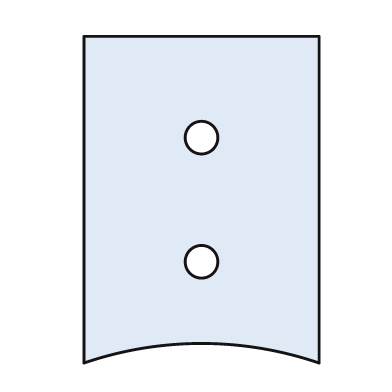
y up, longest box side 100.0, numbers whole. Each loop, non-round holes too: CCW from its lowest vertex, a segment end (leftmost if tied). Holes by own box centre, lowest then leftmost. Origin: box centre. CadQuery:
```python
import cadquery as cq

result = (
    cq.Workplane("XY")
    .moveTo(-36.0, -50.0)
    .threePointArc((0.0, -44.0), (36.0, -50.0))
    .lineTo(36.0, 50.0)
    .lineTo(-36.0, 50.0)
    .close()
    .moveTo(0.0, -19.0)
    .circle(5.0)
    .moveTo(0.0, 19.0)
    .circle(5.0)
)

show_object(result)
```